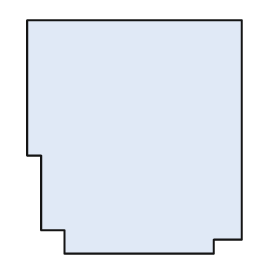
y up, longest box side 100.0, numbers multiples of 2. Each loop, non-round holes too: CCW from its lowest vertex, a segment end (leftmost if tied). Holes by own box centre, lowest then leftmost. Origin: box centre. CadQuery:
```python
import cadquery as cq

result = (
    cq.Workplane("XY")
    .moveTo(-30.0, -50.0)
    .lineTo(34.0, -50.0)
    .lineTo(34.0, -44.0)
    .lineTo(46.0, -44.0)
    .lineTo(46.0, 50.0)
    .lineTo(-46.0, 50.0)
    .lineTo(-46.0, -8.0)
    .lineTo(-40.0, -8.0)
    .lineTo(-40.0, -40.0)
    .lineTo(-30.0, -40.0)
    .close()
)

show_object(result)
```